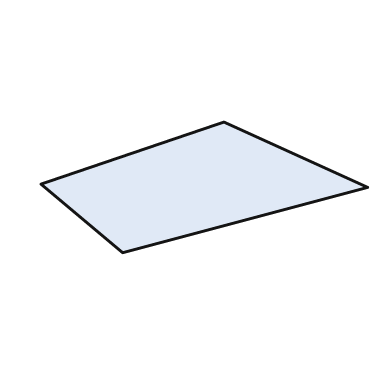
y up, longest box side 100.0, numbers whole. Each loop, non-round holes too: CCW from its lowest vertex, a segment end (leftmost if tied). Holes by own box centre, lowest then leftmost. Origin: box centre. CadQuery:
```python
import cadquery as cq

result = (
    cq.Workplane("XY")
    .moveTo(-25.0, -20.0)
    .lineTo(50.0, 0.0)
    .lineTo(6.0, 20.0)
    .lineTo(-50.0, 1.0)
    .close()
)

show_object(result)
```